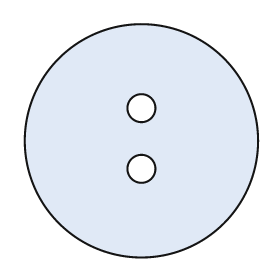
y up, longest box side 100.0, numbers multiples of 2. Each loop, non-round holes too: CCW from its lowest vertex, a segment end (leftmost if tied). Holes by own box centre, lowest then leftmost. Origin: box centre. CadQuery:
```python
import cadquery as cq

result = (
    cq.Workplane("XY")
    .moveTo(0.0, 0.0)
    .circle(50.0)
    .moveTo(0.0, -12.0)
    .circle(6.0)
    .moveTo(0.0, 14.0)
    .circle(6.0)
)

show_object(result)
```